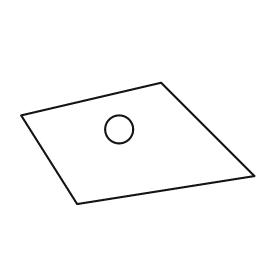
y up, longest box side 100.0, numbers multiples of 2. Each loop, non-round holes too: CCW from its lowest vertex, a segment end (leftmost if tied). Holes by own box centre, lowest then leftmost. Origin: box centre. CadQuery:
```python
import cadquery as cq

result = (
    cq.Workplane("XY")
    .moveTo(-26.0, -26.0)
    .lineTo(50.0, -14.0)
    .lineTo(10.0, 26.0)
    .lineTo(-50.0, 12.0)
    .close()
    .moveTo(-8.0, 6.0)
    .circle(6.0)
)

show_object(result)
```